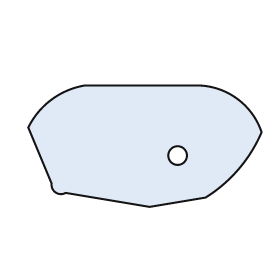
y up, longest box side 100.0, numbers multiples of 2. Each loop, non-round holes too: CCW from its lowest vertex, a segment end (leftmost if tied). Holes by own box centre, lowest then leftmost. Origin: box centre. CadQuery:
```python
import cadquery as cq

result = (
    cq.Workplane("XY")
    .moveTo(2.0, -26.0)
    .lineTo(26.0, -22.0)
    .threePointArc((40.0, -10.0), (50.0, 6.0))
    .threePointArc((40.0, 20.0), (24.0, 26.0))
    .lineTo(-26.0, 26.0)
    .threePointArc((-40.0, 20.0), (-50.0, 8.0))
    .lineTo(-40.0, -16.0)
    .threePointArc((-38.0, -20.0), (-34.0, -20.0))
    .close()
    .moveTo(14.0, -4.0)
    .circle(4.0)
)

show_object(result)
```